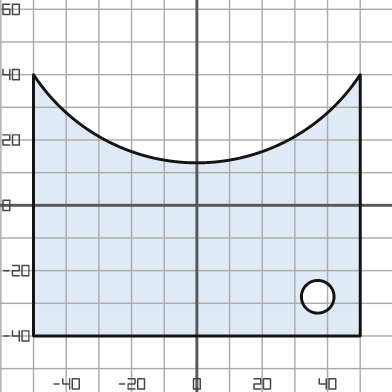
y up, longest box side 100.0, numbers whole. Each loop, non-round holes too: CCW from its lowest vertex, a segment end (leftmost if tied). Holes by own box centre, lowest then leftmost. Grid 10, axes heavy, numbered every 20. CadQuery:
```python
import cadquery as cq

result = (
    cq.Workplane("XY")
    .moveTo(-50.0, -40.0)
    .lineTo(50.0, -40.0)
    .lineTo(50.0, 40.0)
    .threePointArc((0.0, 13.0), (-50.0, 40.0))
    .close()
    .moveTo(37.0, -28.0)
    .circle(5.0)
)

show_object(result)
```